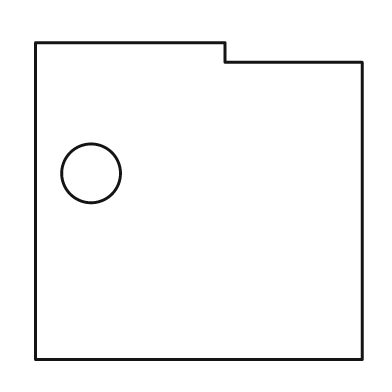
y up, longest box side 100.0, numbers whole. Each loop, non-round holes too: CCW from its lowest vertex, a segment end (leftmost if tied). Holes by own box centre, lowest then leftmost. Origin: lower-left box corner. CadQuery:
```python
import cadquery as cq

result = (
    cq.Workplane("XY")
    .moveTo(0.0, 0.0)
    .lineTo(100.0, 0.0)
    .lineTo(100.0, 91.0)
    .lineTo(58.0, 91.0)
    .lineTo(58.0, 97.0)
    .lineTo(0.0, 97.0)
    .close()
    .moveTo(17.0, 57.0)
    .circle(9.0)
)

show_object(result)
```